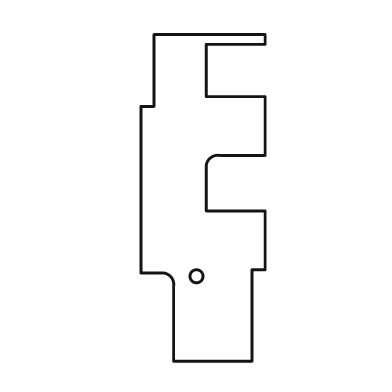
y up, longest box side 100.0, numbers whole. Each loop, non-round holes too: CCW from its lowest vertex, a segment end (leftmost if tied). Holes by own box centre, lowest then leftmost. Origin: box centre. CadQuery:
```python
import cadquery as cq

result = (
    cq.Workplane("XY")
    .moveTo(-9.0, -50.0)
    .lineTo(15.0, -50.0)
    .lineTo(15.0, -22.0)
    .lineTo(19.0, -22.0)
    .lineTo(19.0, -4.0)
    .lineTo(1.0, -4.0)
    .lineTo(1.0, 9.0)
    .threePointArc((2.0, 12.0), (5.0, 13.0))
    .lineTo(19.0, 13.0)
    .lineTo(19.0, 31.0)
    .lineTo(1.0, 31.0)
    .lineTo(1.0, 47.0)
    .lineTo(19.0, 47.0)
    .lineTo(19.0, 50.0)
    .lineTo(-15.0, 50.0)
    .lineTo(-15.0, 28.0)
    .lineTo(-19.0, 28.0)
    .lineTo(-19.0, -23.0)
    .lineTo(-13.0, -23.0)
    .threePointArc((-10.0, -24.0), (-9.0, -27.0))
    .close()
    .moveTo(-2.0, -24.0)
    .circle(2.0)
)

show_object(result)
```